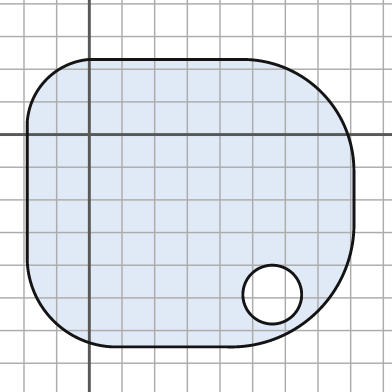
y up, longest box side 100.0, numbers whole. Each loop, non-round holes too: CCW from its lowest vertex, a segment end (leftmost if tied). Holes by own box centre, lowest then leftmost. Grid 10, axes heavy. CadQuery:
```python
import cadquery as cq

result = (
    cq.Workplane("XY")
    .moveTo(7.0, -65.0)
    .lineTo(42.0, -65.0)
    .threePointArc((70.0, -54.0), (81.0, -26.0))
    .lineTo(81.0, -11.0)
    .threePointArc((71.0, 13.0), (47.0, 23.0))
    .lineTo(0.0, 23.0)
    .threePointArc((-13.0, 17.0), (-19.0, 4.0))
    .lineTo(-19.0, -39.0)
    .threePointArc((-11.0, -57.0), (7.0, -65.0))
    .close()
    .moveTo(56.0, -49.0)
    .circle(9.0)
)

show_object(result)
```